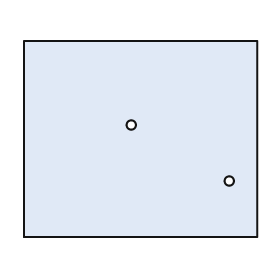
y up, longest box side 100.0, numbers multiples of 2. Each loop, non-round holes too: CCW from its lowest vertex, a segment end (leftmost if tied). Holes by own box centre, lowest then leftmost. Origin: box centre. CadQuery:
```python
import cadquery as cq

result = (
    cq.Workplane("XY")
    .moveTo(-50.0, -42.0)
    .lineTo(50.0, -42.0)
    .lineTo(50.0, 42.0)
    .lineTo(-50.0, 42.0)
    .close()
    .moveTo(38.0, -18.0)
    .circle(2.0)
    .moveTo(-4.0, 6.0)
    .circle(2.0)
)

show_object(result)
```